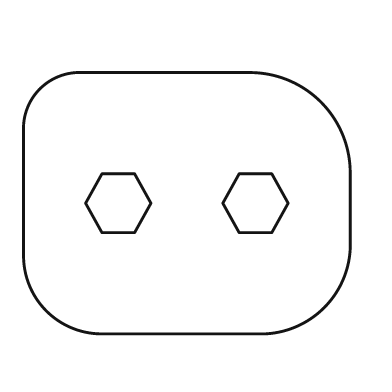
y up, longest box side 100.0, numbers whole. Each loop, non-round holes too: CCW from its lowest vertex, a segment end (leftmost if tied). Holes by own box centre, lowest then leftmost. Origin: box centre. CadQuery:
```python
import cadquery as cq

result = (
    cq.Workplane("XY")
    .moveTo(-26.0, -40.0)
    .lineTo(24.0, -40.0)
    .threePointArc((42.0, -32.0), (50.0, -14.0))
    .lineTo(50.0, 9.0)
    .threePointArc((41.0, 31.0), (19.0, 40.0))
    .lineTo(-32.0, 40.0)
    .threePointArc((-45.0, 35.0), (-50.0, 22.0))
    .lineTo(-50.0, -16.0)
    .threePointArc((-43.0, -33.0), (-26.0, -40.0))
    .close()
    .moveTo(-26.0, -9.0)
    .lineTo(-16.0, -9.0)
    .lineTo(-11.0, 0.0)
    .lineTo(-16.0, 9.0)
    .lineTo(-26.0, 9.0)
    .lineTo(-31.0, 0.0)
    .close()
    .moveTo(16.0, -9.0)
    .lineTo(26.0, -9.0)
    .lineTo(31.0, 0.0)
    .lineTo(26.0, 9.0)
    .lineTo(16.0, 9.0)
    .lineTo(11.0, 0.0)
    .close()
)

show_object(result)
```